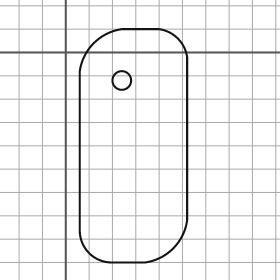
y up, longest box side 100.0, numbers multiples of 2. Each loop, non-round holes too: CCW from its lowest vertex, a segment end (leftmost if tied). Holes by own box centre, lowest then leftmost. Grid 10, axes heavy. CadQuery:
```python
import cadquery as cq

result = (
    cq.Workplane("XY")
    .moveTo(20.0, -90.0)
    .lineTo(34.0, -90.0)
    .threePointArc((46.0, -84.0), (52.0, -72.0))
    .lineTo(52.0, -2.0)
    .threePointArc((48.0, 6.0), (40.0, 10.0))
    .lineTo(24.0, 10.0)
    .threePointArc((12.0, 4.0), (6.0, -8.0))
    .lineTo(6.0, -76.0)
    .threePointArc((10.0, -86.0), (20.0, -90.0))
    .close()
    .moveTo(24.0, -12.0)
    .circle(4.0)
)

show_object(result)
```